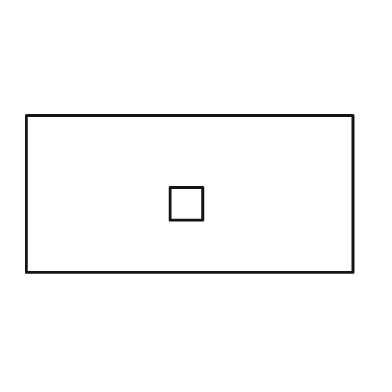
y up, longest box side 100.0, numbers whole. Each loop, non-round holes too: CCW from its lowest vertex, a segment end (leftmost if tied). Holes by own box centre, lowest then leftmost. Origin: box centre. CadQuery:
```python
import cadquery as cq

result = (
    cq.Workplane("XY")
    .moveTo(-50.0, -24.0)
    .lineTo(50.0, -24.0)
    .lineTo(50.0, 24.0)
    .lineTo(-50.0, 24.0)
    .close()
    .moveTo(-6.0, -8.0)
    .lineTo(4.0, -8.0)
    .lineTo(4.0, 2.0)
    .lineTo(-6.0, 2.0)
    .close()
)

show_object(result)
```